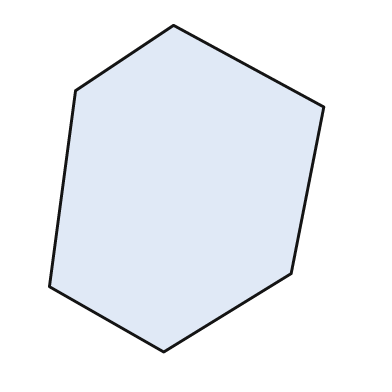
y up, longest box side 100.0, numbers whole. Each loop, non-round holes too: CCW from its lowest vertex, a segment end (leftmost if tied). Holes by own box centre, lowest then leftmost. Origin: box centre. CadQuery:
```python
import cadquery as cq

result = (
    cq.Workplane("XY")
    .moveTo(-7.0, -50.0)
    .lineTo(32.0, -26.0)
    .lineTo(42.0, 25.0)
    .lineTo(-4.0, 50.0)
    .lineTo(-34.0, 30.0)
    .lineTo(-42.0, -30.0)
    .close()
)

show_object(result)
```